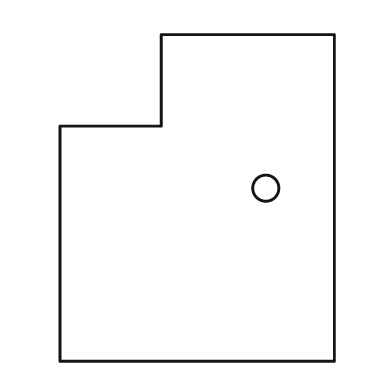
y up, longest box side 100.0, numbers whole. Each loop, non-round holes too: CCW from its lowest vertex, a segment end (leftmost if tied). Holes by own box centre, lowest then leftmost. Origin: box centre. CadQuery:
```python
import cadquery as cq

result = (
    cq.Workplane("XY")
    .moveTo(-42.0, -50.0)
    .lineTo(42.0, -50.0)
    .lineTo(42.0, 50.0)
    .lineTo(-11.0, 50.0)
    .lineTo(-11.0, 22.0)
    .lineTo(-42.0, 22.0)
    .close()
    .moveTo(21.0, 3.0)
    .circle(4.0)
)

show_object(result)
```